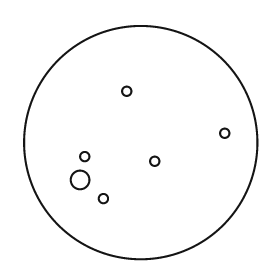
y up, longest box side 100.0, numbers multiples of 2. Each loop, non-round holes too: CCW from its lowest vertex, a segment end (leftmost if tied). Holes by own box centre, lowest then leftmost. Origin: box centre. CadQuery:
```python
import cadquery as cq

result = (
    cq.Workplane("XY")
    .moveTo(0.0, 0.0)
    .circle(50.0)
    .moveTo(-16.0, -24.0)
    .circle(2.0)
    .moveTo(-26.0, -16.0)
    .circle(4.0)
    .moveTo(6.0, -8.0)
    .circle(2.0)
    .moveTo(-24.0, -6.0)
    .circle(2.0)
    .moveTo(36.0, 4.0)
    .circle(2.0)
    .moveTo(-6.0, 22.0)
    .circle(2.0)
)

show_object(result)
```